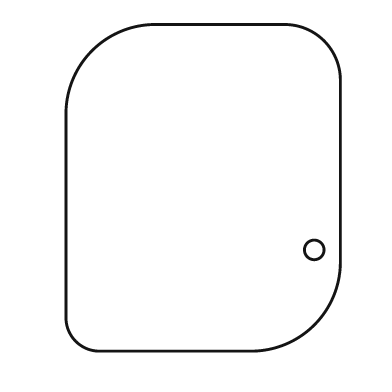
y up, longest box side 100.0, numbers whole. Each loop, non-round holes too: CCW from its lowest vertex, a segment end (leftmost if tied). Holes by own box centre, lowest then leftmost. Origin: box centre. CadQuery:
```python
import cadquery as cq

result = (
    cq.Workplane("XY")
    .moveTo(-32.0, -50.0)
    .lineTo(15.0, -50.0)
    .threePointArc((34.0, -42.0), (42.0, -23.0))
    .lineTo(42.0, 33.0)
    .threePointArc((37.0, 45.0), (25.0, 50.0))
    .lineTo(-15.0, 50.0)
    .threePointArc((-34.0, 42.0), (-42.0, 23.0))
    .lineTo(-42.0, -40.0)
    .threePointArc((-39.0, -47.0), (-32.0, -50.0))
    .close()
    .moveTo(34.0, -19.0)
    .circle(3.0)
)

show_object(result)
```